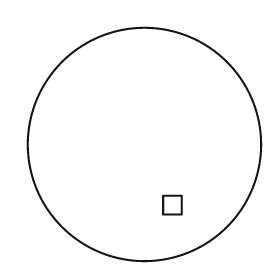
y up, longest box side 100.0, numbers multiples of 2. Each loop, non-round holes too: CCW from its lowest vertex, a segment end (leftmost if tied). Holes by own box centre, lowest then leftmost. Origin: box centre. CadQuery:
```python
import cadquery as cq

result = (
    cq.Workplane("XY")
    .moveTo(0.0, 0.0)
    .circle(50.0)
    .moveTo(8.0, -30.0)
    .lineTo(16.0, -30.0)
    .lineTo(16.0, -22.0)
    .lineTo(8.0, -22.0)
    .close()
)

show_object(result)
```